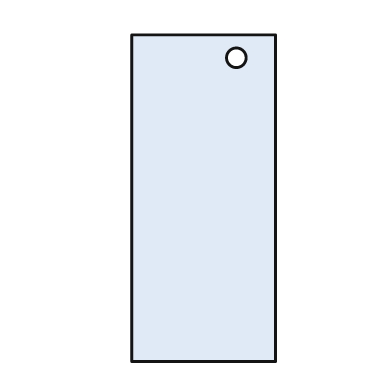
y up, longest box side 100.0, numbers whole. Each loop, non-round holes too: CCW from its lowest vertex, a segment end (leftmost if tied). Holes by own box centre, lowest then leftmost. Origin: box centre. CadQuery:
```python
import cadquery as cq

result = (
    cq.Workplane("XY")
    .moveTo(-22.0, -50.0)
    .lineTo(22.0, -50.0)
    .lineTo(22.0, 50.0)
    .lineTo(-22.0, 50.0)
    .close()
    .moveTo(10.0, 43.0)
    .circle(3.0)
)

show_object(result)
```